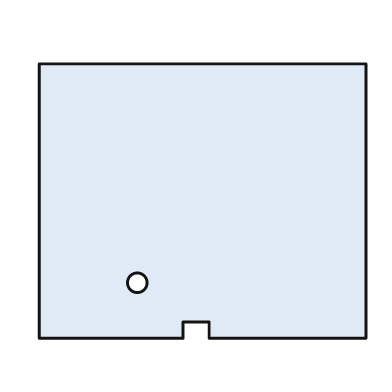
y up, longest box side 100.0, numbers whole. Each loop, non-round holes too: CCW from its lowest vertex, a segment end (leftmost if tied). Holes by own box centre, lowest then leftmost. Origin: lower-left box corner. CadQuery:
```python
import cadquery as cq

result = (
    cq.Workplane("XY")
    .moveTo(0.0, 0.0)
    .lineTo(44.0, 0.0)
    .lineTo(44.0, 5.0)
    .lineTo(52.0, 5.0)
    .lineTo(52.0, 0.0)
    .lineTo(100.0, 0.0)
    .lineTo(100.0, 84.0)
    .lineTo(0.0, 84.0)
    .close()
    .moveTo(30.0, 17.0)
    .circle(3.0)
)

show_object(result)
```